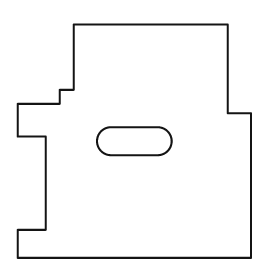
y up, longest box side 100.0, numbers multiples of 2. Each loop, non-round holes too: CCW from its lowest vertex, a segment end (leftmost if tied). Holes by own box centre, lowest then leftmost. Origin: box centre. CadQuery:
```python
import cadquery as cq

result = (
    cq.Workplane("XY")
    .moveTo(-50.0, -50.0)
    .lineTo(50.0, -50.0)
    .lineTo(50.0, 12.0)
    .lineTo(40.0, 12.0)
    .lineTo(40.0, 50.0)
    .lineTo(-26.0, 50.0)
    .lineTo(-26.0, 22.0)
    .lineTo(-32.0, 22.0)
    .lineTo(-32.0, 16.0)
    .lineTo(-50.0, 16.0)
    .lineTo(-50.0, 2.0)
    .lineTo(-38.0, 2.0)
    .lineTo(-38.0, -38.0)
    .lineTo(-50.0, -38.0)
    .close()
    .moveTo(-10.0, -6.0)
    .lineTo(10.0, -6.0)
    .threePointArc((16.0, 0.0), (10.0, 6.0))
    .lineTo(-10.0, 6.0)
    .threePointArc((-16.0, 0.0), (-10.0, -6.0))
    .close()
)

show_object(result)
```